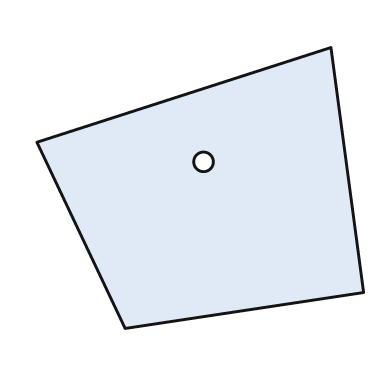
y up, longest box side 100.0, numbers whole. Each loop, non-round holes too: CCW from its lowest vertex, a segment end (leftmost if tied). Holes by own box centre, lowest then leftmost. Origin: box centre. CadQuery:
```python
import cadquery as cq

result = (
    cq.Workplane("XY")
    .moveTo(-23.0, -43.0)
    .lineTo(50.0, -32.0)
    .lineTo(40.0, 43.0)
    .lineTo(-50.0, 14.0)
    .close()
    .moveTo(1.0, 8.0)
    .circle(3.0)
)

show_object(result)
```